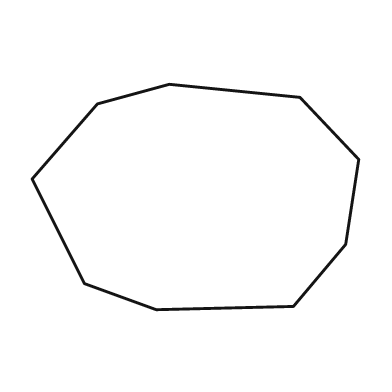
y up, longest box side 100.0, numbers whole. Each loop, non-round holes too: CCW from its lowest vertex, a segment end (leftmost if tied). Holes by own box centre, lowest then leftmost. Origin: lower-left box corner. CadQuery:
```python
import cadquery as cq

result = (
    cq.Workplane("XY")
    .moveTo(38.0, 0.0)
    .lineTo(80.0, 1.0)
    .lineTo(96.0, 20.0)
    .lineTo(100.0, 46.0)
    .lineTo(82.0, 65.0)
    .lineTo(42.0, 69.0)
    .lineTo(20.0, 63.0)
    .lineTo(0.0, 40.0)
    .lineTo(16.0, 8.0)
    .close()
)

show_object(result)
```